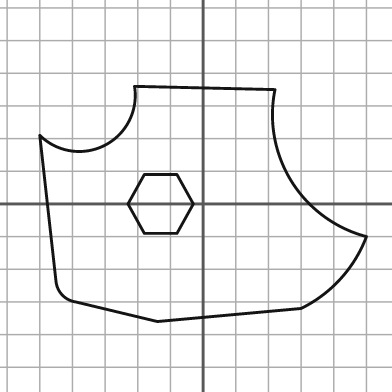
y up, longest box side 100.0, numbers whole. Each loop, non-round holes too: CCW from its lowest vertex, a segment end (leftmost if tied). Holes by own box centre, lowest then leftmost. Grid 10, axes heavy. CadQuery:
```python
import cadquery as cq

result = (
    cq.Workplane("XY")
    .moveTo(-14.0, -36.0)
    .lineTo(30.0, -32.0)
    .threePointArc((42.0, -23.0), (50.0, -10.0))
    .threePointArc((27.0, 7.0), (22.0, 35.0))
    .lineTo(-21.0, 36.0)
    .threePointArc((-30.0, 18.0), (-50.0, 21.0))
    .lineTo(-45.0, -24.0)
    .threePointArc((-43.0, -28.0), (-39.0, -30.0))
    .close()
    .moveTo(-18.0, -9.0)
    .lineTo(-8.0, -9.0)
    .lineTo(-3.0, 0.0)
    .lineTo(-8.0, 9.0)
    .lineTo(-18.0, 9.0)
    .lineTo(-23.0, 0.0)
    .close()
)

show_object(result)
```